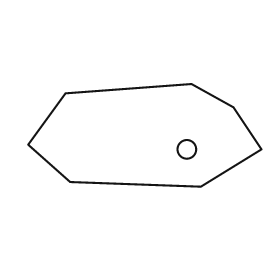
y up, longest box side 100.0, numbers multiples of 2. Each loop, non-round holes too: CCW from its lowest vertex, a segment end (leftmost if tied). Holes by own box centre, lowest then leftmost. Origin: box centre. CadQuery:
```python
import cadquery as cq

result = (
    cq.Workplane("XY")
    .moveTo(24.0, -22.0)
    .lineTo(50.0, -6.0)
    .lineTo(38.0, 12.0)
    .lineTo(20.0, 22.0)
    .lineTo(-34.0, 18.0)
    .lineTo(-50.0, -4.0)
    .lineTo(-32.0, -20.0)
    .close()
    .moveTo(18.0, -6.0)
    .circle(4.0)
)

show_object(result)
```